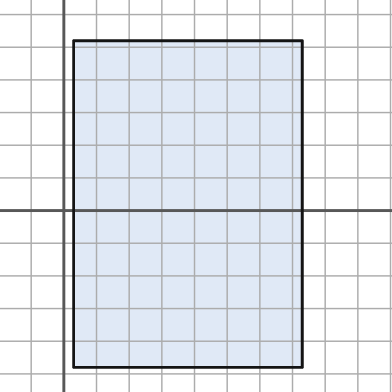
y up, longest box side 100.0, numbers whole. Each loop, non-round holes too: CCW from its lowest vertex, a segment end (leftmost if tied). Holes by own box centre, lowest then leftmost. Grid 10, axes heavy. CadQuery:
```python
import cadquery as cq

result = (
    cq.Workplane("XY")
    .moveTo(3.0, -48.0)
    .lineTo(73.0, -48.0)
    .lineTo(73.0, 52.0)
    .lineTo(3.0, 52.0)
    .close()
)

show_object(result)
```